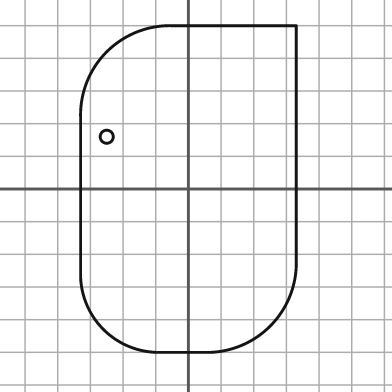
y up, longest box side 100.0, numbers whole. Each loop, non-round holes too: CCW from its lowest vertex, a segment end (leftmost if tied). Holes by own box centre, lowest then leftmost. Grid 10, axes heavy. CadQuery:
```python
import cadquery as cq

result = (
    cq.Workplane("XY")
    .moveTo(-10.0, -50.0)
    .lineTo(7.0, -50.0)
    .threePointArc((25.0, -42.0), (33.0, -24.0))
    .lineTo(33.0, 50.0)
    .lineTo(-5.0, 50.0)
    .threePointArc((-25.0, 42.0), (-33.0, 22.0))
    .lineTo(-33.0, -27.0)
    .threePointArc((-26.0, -43.0), (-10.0, -50.0))
    .close()
    .moveTo(-25.0, 16.0)
    .circle(2.0)
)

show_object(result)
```